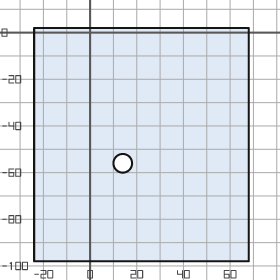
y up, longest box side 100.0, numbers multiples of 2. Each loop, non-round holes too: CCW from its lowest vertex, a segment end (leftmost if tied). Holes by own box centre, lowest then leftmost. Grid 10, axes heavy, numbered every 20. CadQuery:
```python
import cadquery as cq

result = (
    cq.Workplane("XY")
    .moveTo(-24.0, -98.0)
    .lineTo(68.0, -98.0)
    .lineTo(68.0, 2.0)
    .lineTo(-24.0, 2.0)
    .close()
    .moveTo(14.0, -56.0)
    .circle(4.0)
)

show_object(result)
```